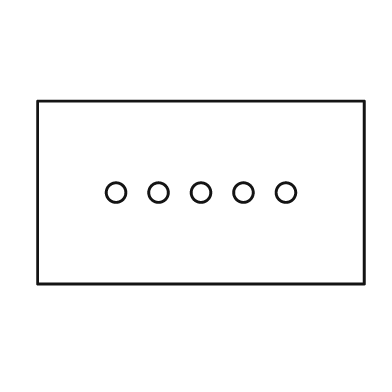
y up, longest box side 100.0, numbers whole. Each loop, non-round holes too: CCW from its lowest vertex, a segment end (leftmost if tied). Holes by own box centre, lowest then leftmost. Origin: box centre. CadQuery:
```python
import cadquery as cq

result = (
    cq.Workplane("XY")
    .moveTo(-50.0, -28.0)
    .lineTo(50.0, -28.0)
    .lineTo(50.0, 28.0)
    .lineTo(-50.0, 28.0)
    .close()
    .moveTo(-26.0, 0.0)
    .circle(3.0)
    .moveTo(-13.0, 0.0)
    .circle(3.0)
    .moveTo(0.0, 0.0)
    .circle(3.0)
    .moveTo(13.0, 0.0)
    .circle(3.0)
    .moveTo(26.0, 0.0)
    .circle(3.0)
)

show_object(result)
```